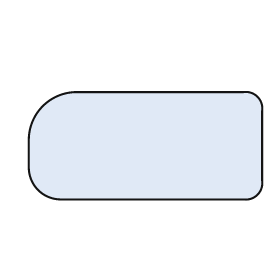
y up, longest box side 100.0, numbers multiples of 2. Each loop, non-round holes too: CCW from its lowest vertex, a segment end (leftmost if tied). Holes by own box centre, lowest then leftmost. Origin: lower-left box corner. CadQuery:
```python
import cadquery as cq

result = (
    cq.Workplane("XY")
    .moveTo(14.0, 0.0)
    .lineTo(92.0, 0.0)
    .threePointArc((98.0, 2.0), (100.0, 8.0))
    .lineTo(100.0, 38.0)
    .threePointArc((98.0, 44.0), (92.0, 46.0))
    .lineTo(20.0, 46.0)
    .threePointArc((6.0, 40.0), (0.0, 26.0))
    .lineTo(0.0, 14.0)
    .threePointArc((4.0, 4.0), (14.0, 0.0))
    .close()
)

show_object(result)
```